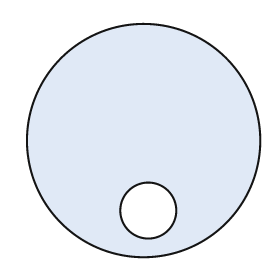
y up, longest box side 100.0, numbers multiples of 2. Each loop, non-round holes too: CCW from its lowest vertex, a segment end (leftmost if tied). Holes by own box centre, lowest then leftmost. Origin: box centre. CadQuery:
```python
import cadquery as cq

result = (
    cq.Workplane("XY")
    .moveTo(0.0, 0.0)
    .circle(50.0)
    .moveTo(2.0, -30.0)
    .circle(12.0)
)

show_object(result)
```